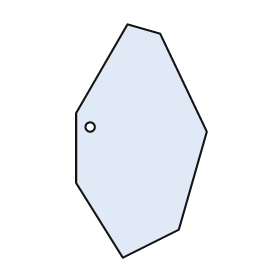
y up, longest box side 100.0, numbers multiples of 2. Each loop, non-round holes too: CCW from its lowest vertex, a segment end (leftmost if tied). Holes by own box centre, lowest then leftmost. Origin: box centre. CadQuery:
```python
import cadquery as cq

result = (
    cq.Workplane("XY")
    .moveTo(-8.0, -50.0)
    .lineTo(16.0, -38.0)
    .lineTo(28.0, 4.0)
    .lineTo(8.0, 46.0)
    .lineTo(-6.0, 50.0)
    .lineTo(-28.0, 12.0)
    .lineTo(-28.0, -18.0)
    .close()
    .moveTo(-22.0, 6.0)
    .circle(2.0)
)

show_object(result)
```